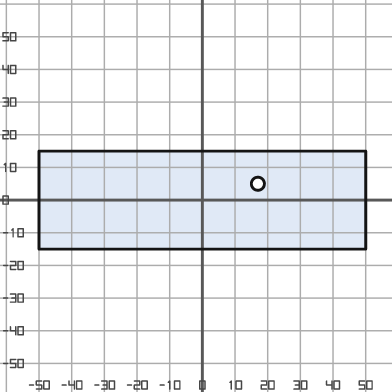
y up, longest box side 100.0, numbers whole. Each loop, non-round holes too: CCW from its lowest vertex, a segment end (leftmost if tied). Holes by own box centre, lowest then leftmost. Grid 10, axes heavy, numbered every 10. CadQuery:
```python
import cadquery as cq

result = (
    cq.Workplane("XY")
    .moveTo(-50.0, -15.0)
    .lineTo(50.0, -15.0)
    .lineTo(50.0, 15.0)
    .lineTo(-50.0, 15.0)
    .close()
    .moveTo(17.0, 5.0)
    .circle(2.0)
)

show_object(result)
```